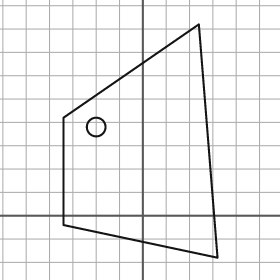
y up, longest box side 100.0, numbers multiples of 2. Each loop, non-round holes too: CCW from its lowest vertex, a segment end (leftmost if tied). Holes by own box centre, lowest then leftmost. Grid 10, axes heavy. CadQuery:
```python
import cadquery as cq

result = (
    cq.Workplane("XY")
    .moveTo(32.0, -18.0)
    .lineTo(24.0, 82.0)
    .lineTo(-34.0, 42.0)
    .lineTo(-34.0, -4.0)
    .close()
    .moveTo(-20.0, 38.0)
    .circle(4.0)
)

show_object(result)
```